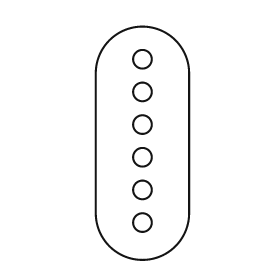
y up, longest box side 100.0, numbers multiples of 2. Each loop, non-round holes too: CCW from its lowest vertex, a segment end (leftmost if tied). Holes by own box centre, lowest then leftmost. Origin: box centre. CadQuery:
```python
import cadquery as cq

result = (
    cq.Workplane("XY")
    .moveTo(-20.0, -30.0)
    .threePointArc((0.0, -50.0), (20.0, -30.0))
    .lineTo(20.0, 30.0)
    .threePointArc((0.0, 50.0), (-20.0, 30.0))
    .close()
    .moveTo(0.0, -34.0)
    .circle(4.0)
    .moveTo(0.0, -20.0)
    .circle(4.0)
    .moveTo(0.0, -6.0)
    .circle(4.0)
    .moveTo(0.0, 8.0)
    .circle(4.0)
    .moveTo(0.0, 22.0)
    .circle(4.0)
    .moveTo(0.0, 36.0)
    .circle(4.0)
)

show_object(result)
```